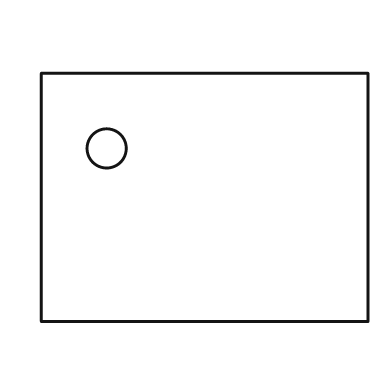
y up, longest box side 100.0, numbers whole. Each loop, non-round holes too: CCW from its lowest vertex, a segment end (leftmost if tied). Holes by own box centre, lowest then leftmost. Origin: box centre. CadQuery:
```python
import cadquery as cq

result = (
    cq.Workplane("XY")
    .moveTo(-50.0, -38.0)
    .lineTo(50.0, -38.0)
    .lineTo(50.0, 38.0)
    .lineTo(-50.0, 38.0)
    .close()
    .moveTo(-30.0, 15.0)
    .circle(6.0)
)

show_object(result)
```